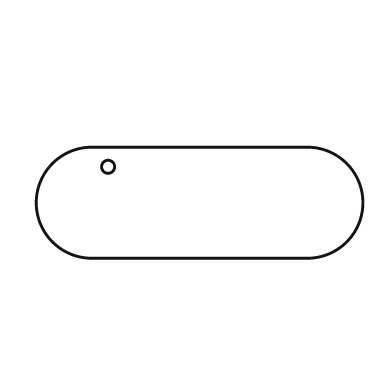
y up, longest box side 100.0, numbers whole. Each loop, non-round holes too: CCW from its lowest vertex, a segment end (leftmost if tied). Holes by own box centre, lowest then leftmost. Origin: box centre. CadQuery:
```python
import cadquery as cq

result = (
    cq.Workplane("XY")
    .moveTo(-33.0, -17.0)
    .lineTo(33.0, -17.0)
    .threePointArc((50.0, 0.0), (33.0, 17.0))
    .lineTo(-33.0, 17.0)
    .threePointArc((-50.0, 0.0), (-33.0, -17.0))
    .close()
    .moveTo(-28.0, 11.0)
    .circle(2.0)
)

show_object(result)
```